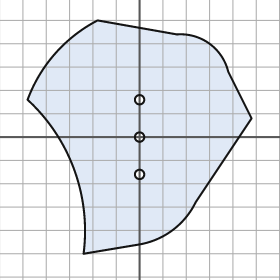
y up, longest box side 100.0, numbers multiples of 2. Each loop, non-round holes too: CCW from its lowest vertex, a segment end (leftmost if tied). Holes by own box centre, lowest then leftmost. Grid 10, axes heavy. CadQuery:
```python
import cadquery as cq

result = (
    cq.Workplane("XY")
    .moveTo(-24.0, -50.0)
    .lineTo(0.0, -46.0)
    .threePointArc((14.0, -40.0), (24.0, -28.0))
    .lineTo(48.0, 8.0)
    .lineTo(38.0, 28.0)
    .threePointArc((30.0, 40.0), (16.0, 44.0))
    .lineTo(-18.0, 50.0)
    .threePointArc((-36.0, 36.0), (-48.0, 16.0))
    .threePointArc((-28.0, -14.0), (-24.0, -50.0))
    .close()
    .moveTo(0.0, -16.0)
    .circle(2.0)
    .moveTo(0.0, 0.0)
    .circle(2.0)
    .moveTo(0.0, 16.0)
    .circle(2.0)
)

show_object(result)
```